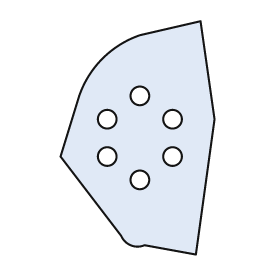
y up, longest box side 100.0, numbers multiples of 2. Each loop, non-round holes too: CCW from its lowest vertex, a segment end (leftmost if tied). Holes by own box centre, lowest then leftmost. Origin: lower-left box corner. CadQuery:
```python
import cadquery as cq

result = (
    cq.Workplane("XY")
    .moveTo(58.0, 0.0)
    .lineTo(66.0, 58.0)
    .lineTo(60.0, 100.0)
    .lineTo(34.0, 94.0)
    .threePointArc((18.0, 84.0), (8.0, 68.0))
    .lineTo(0.0, 42.0)
    .lineTo(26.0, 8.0)
    .threePointArc((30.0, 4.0), (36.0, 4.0))
    .close()
    .moveTo(34.0, 32.0)
    .circle(4.0)
    .moveTo(20.0, 42.0)
    .circle(4.0)
    .moveTo(48.0, 42.0)
    .circle(4.0)
    .moveTo(20.0, 58.0)
    .circle(4.0)
    .moveTo(48.0, 58.0)
    .circle(4.0)
    .moveTo(34.0, 68.0)
    .circle(4.0)
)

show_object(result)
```